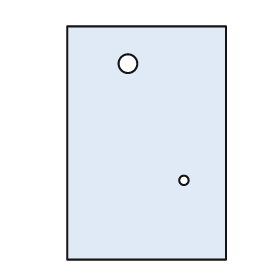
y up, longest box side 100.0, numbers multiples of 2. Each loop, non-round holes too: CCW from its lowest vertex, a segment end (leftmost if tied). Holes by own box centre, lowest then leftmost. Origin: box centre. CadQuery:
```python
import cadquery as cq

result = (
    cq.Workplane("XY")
    .moveTo(-34.0, -50.0)
    .lineTo(34.0, -50.0)
    .lineTo(34.0, 50.0)
    .lineTo(-34.0, 50.0)
    .close()
    .moveTo(16.0, -16.0)
    .circle(2.0)
    .moveTo(-8.0, 34.0)
    .circle(4.0)
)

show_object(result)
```